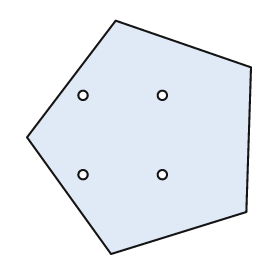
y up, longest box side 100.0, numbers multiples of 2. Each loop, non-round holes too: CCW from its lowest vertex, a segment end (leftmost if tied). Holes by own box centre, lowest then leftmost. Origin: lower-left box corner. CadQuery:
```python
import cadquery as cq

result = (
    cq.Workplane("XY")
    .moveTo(36.0, 0.0)
    .lineTo(94.0, 18.0)
    .lineTo(96.0, 80.0)
    .lineTo(38.0, 100.0)
    .lineTo(0.0, 50.0)
    .close()
    .moveTo(24.0, 34.0)
    .circle(2.0)
    .moveTo(58.0, 34.0)
    .circle(2.0)
    .moveTo(24.0, 68.0)
    .circle(2.0)
    .moveTo(58.0, 68.0)
    .circle(2.0)
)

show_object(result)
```